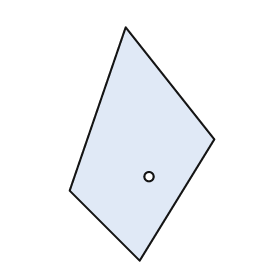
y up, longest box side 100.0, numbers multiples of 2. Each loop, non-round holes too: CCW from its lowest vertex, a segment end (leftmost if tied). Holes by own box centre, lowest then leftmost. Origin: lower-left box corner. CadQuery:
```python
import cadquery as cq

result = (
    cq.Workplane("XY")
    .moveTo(30.0, 0.0)
    .lineTo(62.0, 52.0)
    .lineTo(24.0, 100.0)
    .lineTo(0.0, 30.0)
    .close()
    .moveTo(34.0, 36.0)
    .circle(2.0)
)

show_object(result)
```